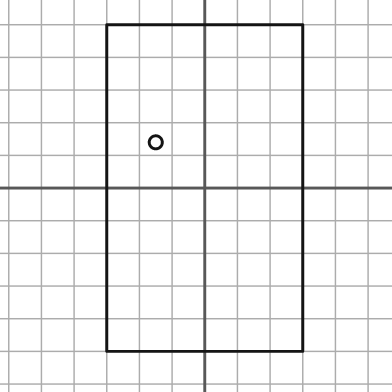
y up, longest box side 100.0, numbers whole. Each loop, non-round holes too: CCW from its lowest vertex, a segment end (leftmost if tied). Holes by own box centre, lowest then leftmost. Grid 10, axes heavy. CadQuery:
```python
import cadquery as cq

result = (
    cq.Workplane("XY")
    .moveTo(-30.0, -50.0)
    .lineTo(30.0, -50.0)
    .lineTo(30.0, 50.0)
    .lineTo(-30.0, 50.0)
    .close()
    .moveTo(-15.0, 14.0)
    .circle(2.0)
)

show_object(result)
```